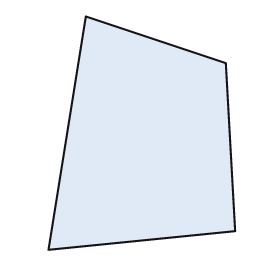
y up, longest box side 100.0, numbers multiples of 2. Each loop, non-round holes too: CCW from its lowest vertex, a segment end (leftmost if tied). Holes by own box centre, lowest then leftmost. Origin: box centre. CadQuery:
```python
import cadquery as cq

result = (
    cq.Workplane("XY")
    .moveTo(-40.0, -50.0)
    .lineTo(40.0, -42.0)
    .lineTo(36.0, 30.0)
    .lineTo(-24.0, 50.0)
    .close()
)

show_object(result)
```